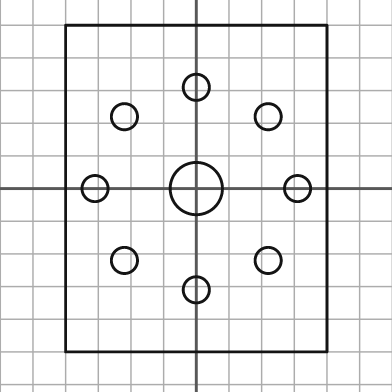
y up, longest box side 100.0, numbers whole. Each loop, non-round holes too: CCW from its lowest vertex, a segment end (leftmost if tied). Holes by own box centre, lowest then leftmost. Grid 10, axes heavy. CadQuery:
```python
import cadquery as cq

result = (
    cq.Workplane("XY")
    .moveTo(-40.0, -50.0)
    .lineTo(40.0, -50.0)
    .lineTo(40.0, 50.0)
    .lineTo(-40.0, 50.0)
    .close()
    .moveTo(0.0, -31.0)
    .circle(4.0)
    .moveTo(-22.0, -22.0)
    .circle(4.0)
    .moveTo(22.0, -22.0)
    .circle(4.0)
    .moveTo(-31.0, 0.0)
    .circle(4.0)
    .moveTo(0.0, 0.0)
    .circle(8.0)
    .moveTo(31.0, 0.0)
    .circle(4.0)
    .moveTo(-22.0, 22.0)
    .circle(4.0)
    .moveTo(22.0, 22.0)
    .circle(4.0)
    .moveTo(0.0, 31.0)
    .circle(4.0)
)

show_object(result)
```